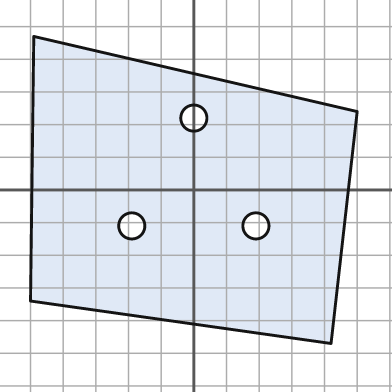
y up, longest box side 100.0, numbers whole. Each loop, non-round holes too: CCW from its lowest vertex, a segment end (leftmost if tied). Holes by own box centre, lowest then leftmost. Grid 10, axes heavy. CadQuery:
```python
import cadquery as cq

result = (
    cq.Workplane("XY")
    .moveTo(42.0, -47.0)
    .lineTo(50.0, 24.0)
    .lineTo(-49.0, 47.0)
    .lineTo(-50.0, -34.0)
    .close()
    .moveTo(-19.0, -11.0)
    .circle(4.0)
    .moveTo(19.0, -11.0)
    .circle(4.0)
    .moveTo(0.0, 22.0)
    .circle(4.0)
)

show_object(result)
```